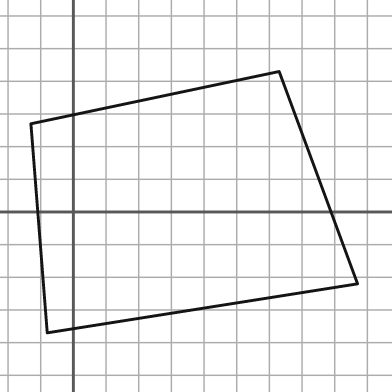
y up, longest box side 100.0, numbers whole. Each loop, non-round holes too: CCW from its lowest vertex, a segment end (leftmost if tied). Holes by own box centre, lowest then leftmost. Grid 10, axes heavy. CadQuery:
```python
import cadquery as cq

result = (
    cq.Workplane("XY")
    .moveTo(-8.0, -37.0)
    .lineTo(87.0, -22.0)
    .lineTo(63.0, 43.0)
    .lineTo(-13.0, 27.0)
    .close()
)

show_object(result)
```